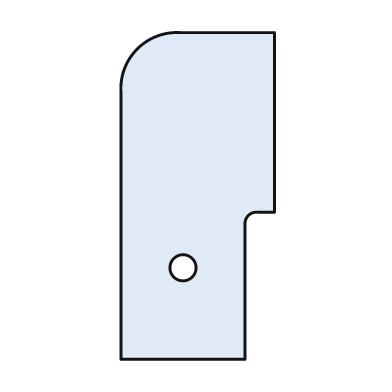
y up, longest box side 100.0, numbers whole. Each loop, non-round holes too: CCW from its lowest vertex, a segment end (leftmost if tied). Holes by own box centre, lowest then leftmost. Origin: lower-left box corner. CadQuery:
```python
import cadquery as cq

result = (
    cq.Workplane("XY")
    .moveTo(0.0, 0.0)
    .lineTo(38.0, 0.0)
    .lineTo(38.0, 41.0)
    .threePointArc((39.0, 44.0), (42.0, 45.0))
    .lineTo(47.0, 45.0)
    .lineTo(47.0, 100.0)
    .lineTo(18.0, 100.0)
    .threePointArc((5.0, 95.0), (0.0, 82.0))
    .close()
    .moveTo(19.0, 28.0)
    .circle(4.0)
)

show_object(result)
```